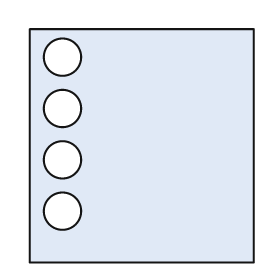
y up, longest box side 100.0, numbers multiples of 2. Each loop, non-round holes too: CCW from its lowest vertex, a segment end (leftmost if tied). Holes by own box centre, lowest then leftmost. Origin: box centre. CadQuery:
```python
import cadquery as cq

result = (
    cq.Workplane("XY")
    .moveTo(-48.0, -50.0)
    .lineTo(48.0, -50.0)
    .lineTo(48.0, 50.0)
    .lineTo(-48.0, 50.0)
    .close()
    .moveTo(-34.0, -28.0)
    .circle(8.0)
    .moveTo(-34.0, -6.0)
    .circle(8.0)
    .moveTo(-34.0, 16.0)
    .circle(8.0)
    .moveTo(-34.0, 38.0)
    .circle(8.0)
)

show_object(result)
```